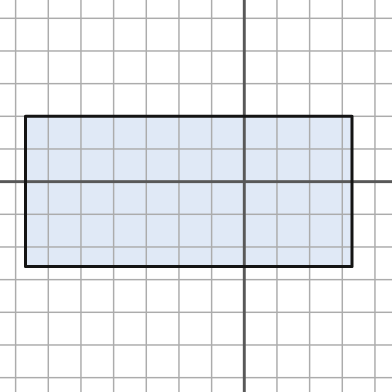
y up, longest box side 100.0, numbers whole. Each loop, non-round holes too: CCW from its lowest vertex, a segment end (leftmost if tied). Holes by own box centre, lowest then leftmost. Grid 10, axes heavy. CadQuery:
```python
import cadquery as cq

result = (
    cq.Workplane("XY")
    .moveTo(-67.0, -26.0)
    .lineTo(33.0, -26.0)
    .lineTo(33.0, 20.0)
    .lineTo(-67.0, 20.0)
    .close()
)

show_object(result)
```